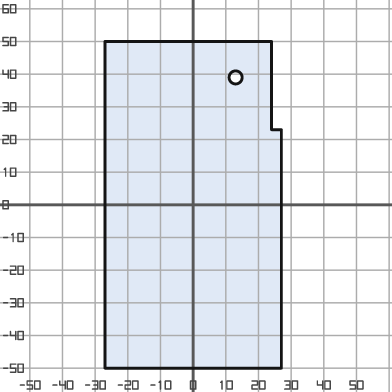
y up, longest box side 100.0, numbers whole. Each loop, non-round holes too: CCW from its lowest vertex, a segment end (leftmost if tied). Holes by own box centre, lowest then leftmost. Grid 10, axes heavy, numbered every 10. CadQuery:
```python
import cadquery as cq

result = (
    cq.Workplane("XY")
    .moveTo(-27.0, -50.0)
    .lineTo(27.0, -50.0)
    .lineTo(27.0, 23.0)
    .lineTo(24.0, 23.0)
    .lineTo(24.0, 50.0)
    .lineTo(-27.0, 50.0)
    .close()
    .moveTo(13.0, 39.0)
    .circle(2.0)
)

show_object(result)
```